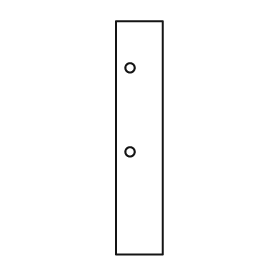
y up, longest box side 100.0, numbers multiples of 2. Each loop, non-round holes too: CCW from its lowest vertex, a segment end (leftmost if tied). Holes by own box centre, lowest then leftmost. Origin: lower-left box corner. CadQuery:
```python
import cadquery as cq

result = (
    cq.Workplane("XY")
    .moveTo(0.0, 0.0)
    .lineTo(20.0, 0.0)
    .lineTo(20.0, 100.0)
    .lineTo(0.0, 100.0)
    .close()
    .moveTo(6.0, 44.0)
    .circle(2.0)
    .moveTo(6.0, 80.0)
    .circle(2.0)
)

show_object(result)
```